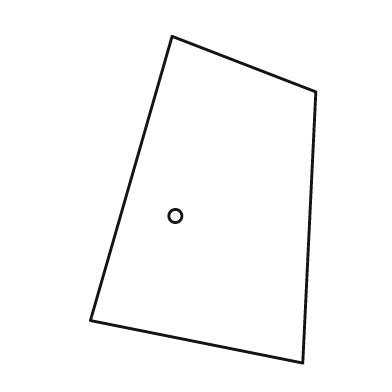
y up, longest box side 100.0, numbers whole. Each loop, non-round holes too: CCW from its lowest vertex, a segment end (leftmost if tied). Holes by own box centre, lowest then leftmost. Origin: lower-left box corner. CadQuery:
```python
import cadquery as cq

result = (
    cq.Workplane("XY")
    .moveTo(65.0, 0.0)
    .lineTo(69.0, 83.0)
    .lineTo(25.0, 100.0)
    .lineTo(0.0, 13.0)
    .close()
    .moveTo(26.0, 45.0)
    .circle(2.0)
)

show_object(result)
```